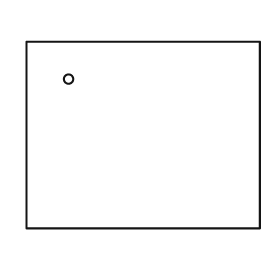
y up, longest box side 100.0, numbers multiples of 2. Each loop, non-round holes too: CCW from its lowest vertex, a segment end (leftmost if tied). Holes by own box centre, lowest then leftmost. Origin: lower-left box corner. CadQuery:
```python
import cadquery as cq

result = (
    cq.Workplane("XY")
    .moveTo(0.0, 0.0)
    .lineTo(100.0, 0.0)
    .lineTo(100.0, 80.0)
    .lineTo(0.0, 80.0)
    .close()
    .moveTo(18.0, 64.0)
    .circle(2.0)
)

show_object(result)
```